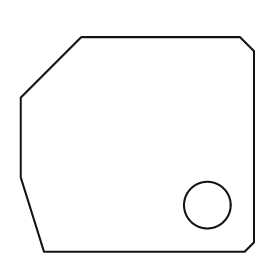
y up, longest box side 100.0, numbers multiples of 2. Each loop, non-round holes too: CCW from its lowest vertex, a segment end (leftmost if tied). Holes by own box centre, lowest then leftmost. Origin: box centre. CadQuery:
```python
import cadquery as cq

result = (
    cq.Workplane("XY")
    .moveTo(-40.0, -46.0)
    .lineTo(46.0, -46.0)
    .lineTo(50.0, -42.0)
    .lineTo(50.0, 40.0)
    .lineTo(44.0, 46.0)
    .lineTo(-24.0, 46.0)
    .lineTo(-50.0, 20.0)
    .lineTo(-50.0, -14.0)
    .close()
    .moveTo(30.0, -26.0)
    .circle(10.0)
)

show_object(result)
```